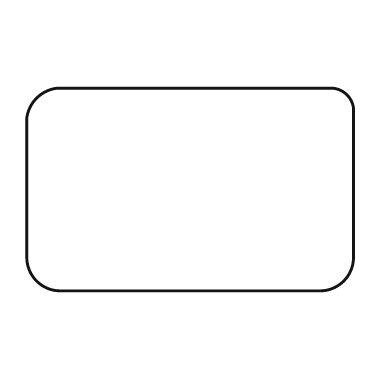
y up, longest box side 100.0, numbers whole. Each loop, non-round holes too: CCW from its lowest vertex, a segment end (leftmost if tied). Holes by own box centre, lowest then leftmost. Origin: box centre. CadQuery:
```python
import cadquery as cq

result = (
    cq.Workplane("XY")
    .moveTo(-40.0, -31.0)
    .lineTo(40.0, -31.0)
    .threePointArc((47.0, -28.0), (50.0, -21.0))
    .lineTo(50.0, 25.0)
    .threePointArc((48.0, 29.0), (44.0, 31.0))
    .lineTo(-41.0, 31.0)
    .threePointArc((-47.0, 28.0), (-50.0, 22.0))
    .lineTo(-50.0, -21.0)
    .threePointArc((-47.0, -28.0), (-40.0, -31.0))
    .close()
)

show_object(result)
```